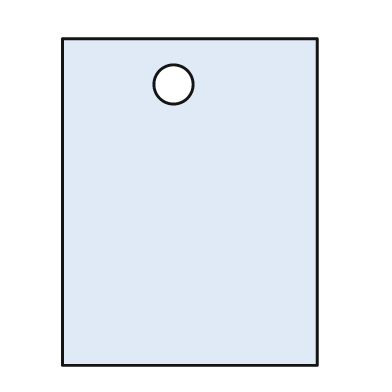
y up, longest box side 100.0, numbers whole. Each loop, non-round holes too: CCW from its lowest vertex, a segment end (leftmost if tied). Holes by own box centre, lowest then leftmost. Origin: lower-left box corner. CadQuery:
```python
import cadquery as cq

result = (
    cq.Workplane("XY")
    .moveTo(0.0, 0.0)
    .lineTo(78.0, 0.0)
    .lineTo(78.0, 100.0)
    .lineTo(0.0, 100.0)
    .close()
    .moveTo(34.0, 86.0)
    .circle(6.0)
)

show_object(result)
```